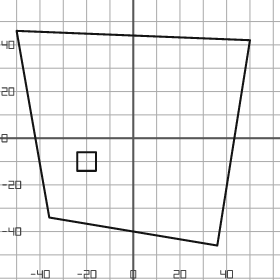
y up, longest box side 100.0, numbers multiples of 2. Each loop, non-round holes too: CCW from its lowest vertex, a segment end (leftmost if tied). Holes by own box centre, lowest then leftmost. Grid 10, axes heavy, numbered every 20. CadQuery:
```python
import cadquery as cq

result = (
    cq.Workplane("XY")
    .moveTo(36.0, -46.0)
    .lineTo(50.0, 42.0)
    .lineTo(-50.0, 46.0)
    .lineTo(-36.0, -34.0)
    .close()
    .moveTo(-24.0, -14.0)
    .lineTo(-16.0, -14.0)
    .lineTo(-16.0, -6.0)
    .lineTo(-24.0, -6.0)
    .close()
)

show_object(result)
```